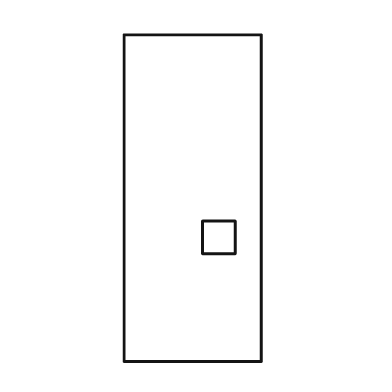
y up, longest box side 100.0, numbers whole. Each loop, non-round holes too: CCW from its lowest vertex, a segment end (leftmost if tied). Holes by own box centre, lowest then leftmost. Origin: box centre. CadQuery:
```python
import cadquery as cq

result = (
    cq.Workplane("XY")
    .moveTo(-21.0, -50.0)
    .lineTo(21.0, -50.0)
    .lineTo(21.0, 50.0)
    .lineTo(-21.0, 50.0)
    .close()
    .moveTo(3.0, -17.0)
    .lineTo(13.0, -17.0)
    .lineTo(13.0, -7.0)
    .lineTo(3.0, -7.0)
    .close()
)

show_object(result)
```